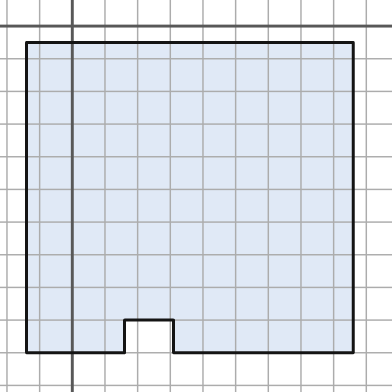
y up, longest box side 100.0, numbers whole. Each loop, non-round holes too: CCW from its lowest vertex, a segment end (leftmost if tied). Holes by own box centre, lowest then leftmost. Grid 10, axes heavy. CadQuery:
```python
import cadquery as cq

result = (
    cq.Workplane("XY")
    .moveTo(-14.0, -100.0)
    .lineTo(16.0, -100.0)
    .lineTo(16.0, -90.0)
    .lineTo(31.0, -90.0)
    .lineTo(31.0, -100.0)
    .lineTo(86.0, -100.0)
    .lineTo(86.0, -5.0)
    .lineTo(-14.0, -5.0)
    .close()
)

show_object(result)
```